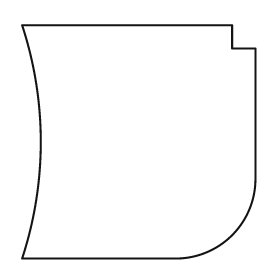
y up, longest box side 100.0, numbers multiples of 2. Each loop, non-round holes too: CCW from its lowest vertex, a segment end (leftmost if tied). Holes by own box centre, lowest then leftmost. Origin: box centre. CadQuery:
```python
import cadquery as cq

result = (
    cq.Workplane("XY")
    .moveTo(-50.0, -50.0)
    .lineTo(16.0, -50.0)
    .threePointArc((40.0, -40.0), (50.0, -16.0))
    .lineTo(50.0, 40.0)
    .lineTo(40.0, 40.0)
    .lineTo(40.0, 50.0)
    .lineTo(-50.0, 50.0)
    .threePointArc((-42.0, 0.0), (-50.0, -50.0))
    .close()
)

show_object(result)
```